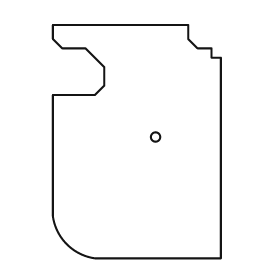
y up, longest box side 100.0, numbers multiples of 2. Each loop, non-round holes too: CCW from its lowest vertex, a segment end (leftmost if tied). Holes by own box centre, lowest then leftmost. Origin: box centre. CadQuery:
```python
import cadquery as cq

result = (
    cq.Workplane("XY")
    .moveTo(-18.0, -50.0)
    .lineTo(36.0, -50.0)
    .lineTo(36.0, 36.0)
    .lineTo(32.0, 36.0)
    .lineTo(32.0, 40.0)
    .lineTo(26.0, 40.0)
    .lineTo(22.0, 44.0)
    .lineTo(22.0, 50.0)
    .lineTo(-36.0, 50.0)
    .lineTo(-36.0, 44.0)
    .lineTo(-32.0, 40.0)
    .lineTo(-22.0, 40.0)
    .lineTo(-14.0, 32.0)
    .lineTo(-14.0, 24.0)
    .lineTo(-18.0, 20.0)
    .lineTo(-36.0, 20.0)
    .lineTo(-36.0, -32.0)
    .threePointArc((-30.0, -44.0), (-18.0, -50.0))
    .close()
    .moveTo(8.0, 2.0)
    .circle(2.0)
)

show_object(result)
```